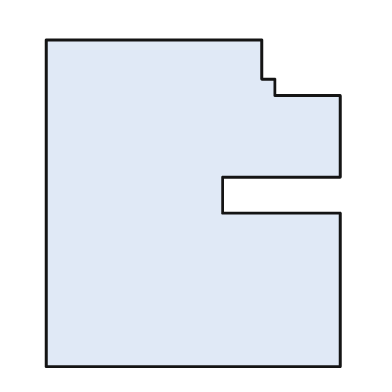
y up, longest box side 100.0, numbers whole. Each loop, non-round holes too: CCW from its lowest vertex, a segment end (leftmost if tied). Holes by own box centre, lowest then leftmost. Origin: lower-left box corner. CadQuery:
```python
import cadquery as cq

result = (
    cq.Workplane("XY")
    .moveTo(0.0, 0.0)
    .lineTo(90.0, 0.0)
    .lineTo(90.0, 47.0)
    .lineTo(54.0, 47.0)
    .lineTo(54.0, 58.0)
    .lineTo(90.0, 58.0)
    .lineTo(90.0, 83.0)
    .lineTo(70.0, 83.0)
    .lineTo(70.0, 88.0)
    .lineTo(66.0, 88.0)
    .lineTo(66.0, 100.0)
    .lineTo(0.0, 100.0)
    .close()
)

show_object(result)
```